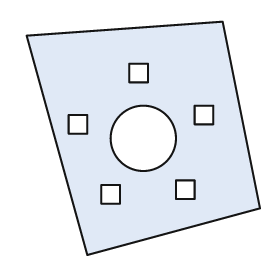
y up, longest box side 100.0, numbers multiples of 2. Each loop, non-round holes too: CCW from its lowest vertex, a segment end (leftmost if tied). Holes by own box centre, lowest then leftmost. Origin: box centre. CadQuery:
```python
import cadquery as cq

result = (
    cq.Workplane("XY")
    .moveTo(-24.0, -50.0)
    .lineTo(50.0, -30.0)
    .lineTo(34.0, 50.0)
    .lineTo(-50.0, 44.0)
    .close()
    .moveTo(-18.0, -28.0)
    .lineTo(-10.0, -28.0)
    .lineTo(-10.0, -20.0)
    .lineTo(-18.0, -20.0)
    .close()
    .moveTo(14.0, -26.0)
    .lineTo(22.0, -26.0)
    .lineTo(22.0, -18.0)
    .lineTo(14.0, -18.0)
    .close()
    .moveTo(0.0, 0.0)
    .circle(14.0)
    .moveTo(-32.0, 2.0)
    .lineTo(-24.0, 2.0)
    .lineTo(-24.0, 10.0)
    .lineTo(-32.0, 10.0)
    .close()
    .moveTo(22.0, 6.0)
    .lineTo(30.0, 6.0)
    .lineTo(30.0, 14.0)
    .lineTo(22.0, 14.0)
    .close()
    .moveTo(-6.0, 24.0)
    .lineTo(2.0, 24.0)
    .lineTo(2.0, 32.0)
    .lineTo(-6.0, 32.0)
    .close()
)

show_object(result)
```